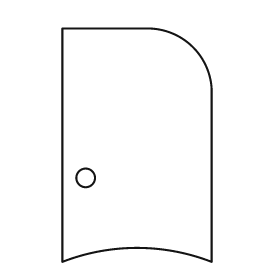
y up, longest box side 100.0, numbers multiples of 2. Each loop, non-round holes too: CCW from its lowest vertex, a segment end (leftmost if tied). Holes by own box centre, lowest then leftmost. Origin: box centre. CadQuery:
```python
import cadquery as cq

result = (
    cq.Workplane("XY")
    .moveTo(-32.0, -50.0)
    .threePointArc((0.0, -44.0), (32.0, -50.0))
    .lineTo(32.0, 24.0)
    .threePointArc((24.0, 42.0), (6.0, 50.0))
    .lineTo(-32.0, 50.0)
    .close()
    .moveTo(-22.0, -14.0)
    .circle(4.0)
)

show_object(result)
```